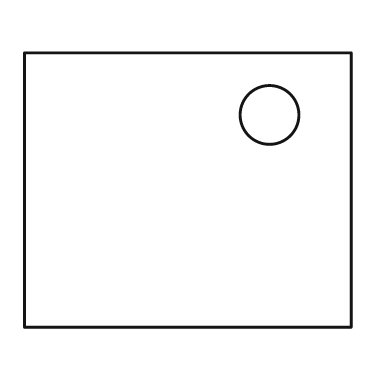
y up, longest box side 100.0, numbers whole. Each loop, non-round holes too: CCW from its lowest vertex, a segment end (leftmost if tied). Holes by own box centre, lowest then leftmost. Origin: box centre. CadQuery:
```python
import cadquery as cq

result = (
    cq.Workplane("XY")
    .moveTo(-50.0, -42.0)
    .lineTo(50.0, -42.0)
    .lineTo(50.0, 42.0)
    .lineTo(-50.0, 42.0)
    .close()
    .moveTo(25.0, 23.0)
    .circle(9.0)
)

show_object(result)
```